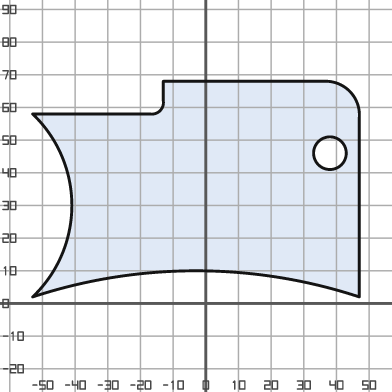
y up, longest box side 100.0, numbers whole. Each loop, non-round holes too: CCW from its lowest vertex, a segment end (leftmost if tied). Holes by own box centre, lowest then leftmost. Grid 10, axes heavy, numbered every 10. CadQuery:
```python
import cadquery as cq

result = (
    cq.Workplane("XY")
    .moveTo(-53.0, 2.0)
    .threePointArc((-3.0, 10.0), (47.0, 2.0))
    .lineTo(47.0, 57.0)
    .threePointArc((44.0, 65.0), (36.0, 68.0))
    .lineTo(-13.0, 68.0)
    .lineTo(-13.0, 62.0)
    .threePointArc((-14.0, 59.0), (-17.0, 58.0))
    .lineTo(-53.0, 58.0)
    .threePointArc((-41.0, 30.0), (-53.0, 2.0))
    .close()
    .moveTo(38.0, 46.0)
    .circle(5.0)
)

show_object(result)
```